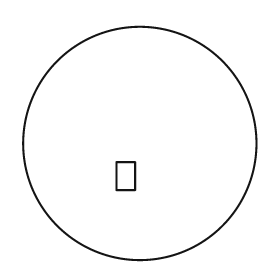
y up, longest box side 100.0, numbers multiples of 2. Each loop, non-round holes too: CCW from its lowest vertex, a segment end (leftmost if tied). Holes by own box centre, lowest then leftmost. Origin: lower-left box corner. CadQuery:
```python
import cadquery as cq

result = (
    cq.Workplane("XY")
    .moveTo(50.0, 50.0)
    .circle(50.0)
    .moveTo(40.0, 30.0)
    .lineTo(48.0, 30.0)
    .lineTo(48.0, 42.0)
    .lineTo(40.0, 42.0)
    .close()
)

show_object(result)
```